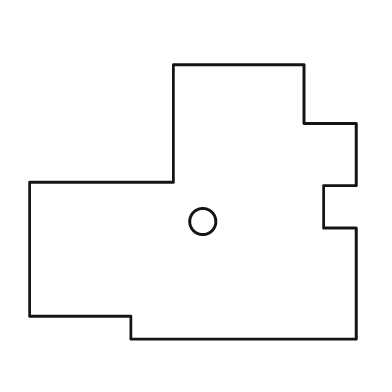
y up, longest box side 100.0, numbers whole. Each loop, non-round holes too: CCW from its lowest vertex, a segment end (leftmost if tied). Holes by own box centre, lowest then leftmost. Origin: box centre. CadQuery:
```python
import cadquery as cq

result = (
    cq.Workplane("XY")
    .moveTo(-19.0, -42.0)
    .lineTo(50.0, -42.0)
    .lineTo(50.0, -8.0)
    .lineTo(40.0, -8.0)
    .lineTo(40.0, 5.0)
    .lineTo(50.0, 5.0)
    .lineTo(50.0, 24.0)
    .lineTo(34.0, 24.0)
    .lineTo(34.0, 42.0)
    .lineTo(-6.0, 42.0)
    .lineTo(-6.0, 6.0)
    .lineTo(-50.0, 6.0)
    .lineTo(-50.0, -35.0)
    .lineTo(-19.0, -35.0)
    .close()
    .moveTo(3.0, -6.0)
    .circle(4.0)
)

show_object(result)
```